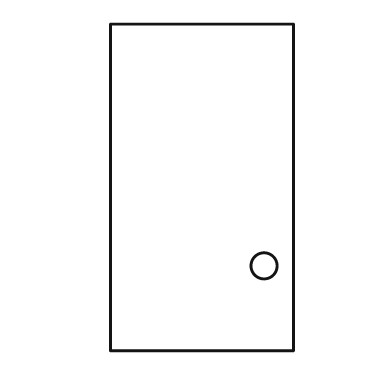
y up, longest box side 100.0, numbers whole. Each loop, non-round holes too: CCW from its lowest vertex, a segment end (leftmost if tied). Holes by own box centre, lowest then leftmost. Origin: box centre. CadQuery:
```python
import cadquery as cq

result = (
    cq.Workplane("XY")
    .moveTo(-28.0, -50.0)
    .lineTo(28.0, -50.0)
    .lineTo(28.0, 50.0)
    .lineTo(-28.0, 50.0)
    .close()
    .moveTo(19.0, -24.0)
    .circle(4.0)
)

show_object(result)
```